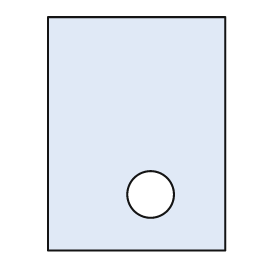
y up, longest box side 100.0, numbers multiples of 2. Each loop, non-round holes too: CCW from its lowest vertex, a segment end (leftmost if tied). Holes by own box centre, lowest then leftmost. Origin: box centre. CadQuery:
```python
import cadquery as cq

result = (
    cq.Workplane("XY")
    .moveTo(-38.0, -50.0)
    .lineTo(38.0, -50.0)
    .lineTo(38.0, 50.0)
    .lineTo(-38.0, 50.0)
    .close()
    .moveTo(6.0, -26.0)
    .circle(10.0)
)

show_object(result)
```